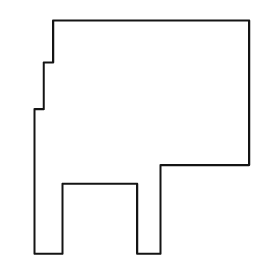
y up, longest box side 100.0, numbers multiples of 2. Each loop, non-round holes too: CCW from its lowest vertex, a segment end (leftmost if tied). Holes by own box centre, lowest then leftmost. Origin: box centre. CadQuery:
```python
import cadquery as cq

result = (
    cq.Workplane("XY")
    .moveTo(-46.0, -50.0)
    .lineTo(-34.0, -50.0)
    .lineTo(-34.0, -20.0)
    .lineTo(-2.0, -20.0)
    .lineTo(-2.0, -50.0)
    .lineTo(8.0, -50.0)
    .lineTo(8.0, -12.0)
    .lineTo(46.0, -12.0)
    .lineTo(46.0, 50.0)
    .lineTo(-38.0, 50.0)
    .lineTo(-38.0, 32.0)
    .lineTo(-42.0, 32.0)
    .lineTo(-42.0, 12.0)
    .lineTo(-46.0, 12.0)
    .close()
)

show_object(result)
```